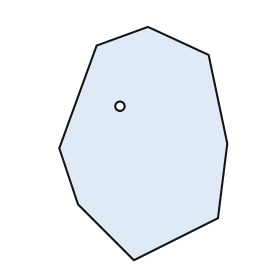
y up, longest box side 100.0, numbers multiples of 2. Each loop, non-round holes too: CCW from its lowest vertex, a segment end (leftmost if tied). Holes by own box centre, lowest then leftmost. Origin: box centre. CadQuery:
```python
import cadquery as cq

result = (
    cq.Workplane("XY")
    .moveTo(-4.0, -50.0)
    .lineTo(32.0, -32.0)
    .lineTo(36.0, 0.0)
    .lineTo(28.0, 38.0)
    .lineTo(2.0, 50.0)
    .lineTo(-20.0, 42.0)
    .lineTo(-36.0, -2.0)
    .lineTo(-28.0, -26.0)
    .close()
    .moveTo(-10.0, 16.0)
    .circle(2.0)
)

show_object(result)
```